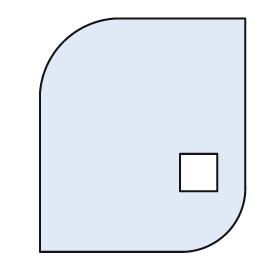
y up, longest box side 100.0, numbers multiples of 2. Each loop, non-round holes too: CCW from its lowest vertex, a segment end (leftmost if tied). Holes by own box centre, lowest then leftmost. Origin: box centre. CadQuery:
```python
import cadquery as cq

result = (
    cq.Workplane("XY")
    .moveTo(-44.0, -50.0)
    .lineTo(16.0, -50.0)
    .threePointArc((36.0, -42.0), (44.0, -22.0))
    .lineTo(44.0, 50.0)
    .lineTo(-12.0, 50.0)
    .threePointArc((-34.0, 40.0), (-44.0, 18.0))
    .close()
    .moveTo(16.0, -24.0)
    .lineTo(32.0, -24.0)
    .lineTo(32.0, -8.0)
    .lineTo(16.0, -8.0)
    .close()
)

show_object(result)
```